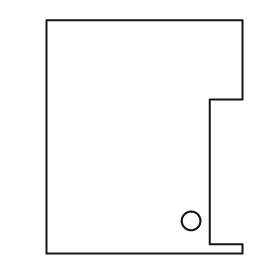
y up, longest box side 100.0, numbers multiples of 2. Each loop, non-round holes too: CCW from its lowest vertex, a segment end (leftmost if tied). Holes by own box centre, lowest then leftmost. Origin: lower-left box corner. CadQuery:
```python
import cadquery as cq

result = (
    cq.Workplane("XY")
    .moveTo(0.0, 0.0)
    .lineTo(84.0, 0.0)
    .lineTo(84.0, 4.0)
    .lineTo(70.0, 4.0)
    .lineTo(70.0, 66.0)
    .lineTo(84.0, 66.0)
    .lineTo(84.0, 100.0)
    .lineTo(0.0, 100.0)
    .close()
    .moveTo(62.0, 14.0)
    .circle(4.0)
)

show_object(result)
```